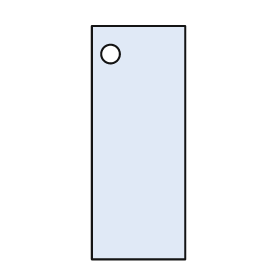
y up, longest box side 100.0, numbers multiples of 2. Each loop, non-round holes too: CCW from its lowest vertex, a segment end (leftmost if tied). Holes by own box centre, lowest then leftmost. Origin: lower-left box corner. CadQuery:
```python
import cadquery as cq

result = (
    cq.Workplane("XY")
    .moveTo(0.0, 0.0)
    .lineTo(40.0, 0.0)
    .lineTo(40.0, 100.0)
    .lineTo(0.0, 100.0)
    .close()
    .moveTo(8.0, 88.0)
    .circle(4.0)
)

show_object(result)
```